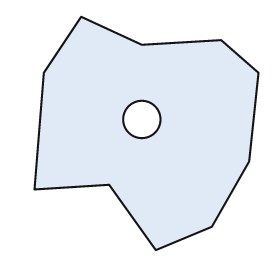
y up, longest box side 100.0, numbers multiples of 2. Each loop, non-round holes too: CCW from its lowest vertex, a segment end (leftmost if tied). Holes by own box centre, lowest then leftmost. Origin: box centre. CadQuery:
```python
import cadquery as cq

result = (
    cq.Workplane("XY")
    .moveTo(4.0, -50.0)
    .lineTo(28.0, -40.0)
    .lineTo(44.0, -12.0)
    .lineTo(48.0, 26.0)
    .lineTo(32.0, 40.0)
    .lineTo(-2.0, 38.0)
    .lineTo(-28.0, 50.0)
    .lineTo(-44.0, 26.0)
    .lineTo(-48.0, -24.0)
    .lineTo(-16.0, -22.0)
    .close()
    .moveTo(-2.0, 6.0)
    .circle(8.0)
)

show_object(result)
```